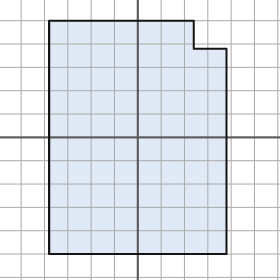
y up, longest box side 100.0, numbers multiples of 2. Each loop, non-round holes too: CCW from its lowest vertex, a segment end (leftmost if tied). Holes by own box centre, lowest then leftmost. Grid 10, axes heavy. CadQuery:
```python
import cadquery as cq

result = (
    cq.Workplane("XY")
    .moveTo(-38.0, -50.0)
    .lineTo(38.0, -50.0)
    .lineTo(38.0, 38.0)
    .lineTo(24.0, 38.0)
    .lineTo(24.0, 50.0)
    .lineTo(-38.0, 50.0)
    .close()
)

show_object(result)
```